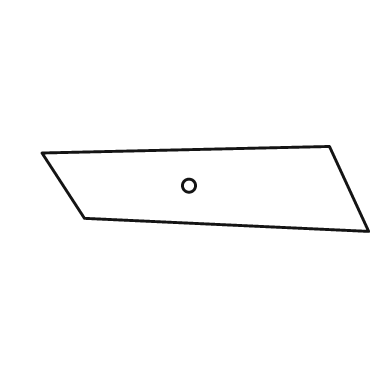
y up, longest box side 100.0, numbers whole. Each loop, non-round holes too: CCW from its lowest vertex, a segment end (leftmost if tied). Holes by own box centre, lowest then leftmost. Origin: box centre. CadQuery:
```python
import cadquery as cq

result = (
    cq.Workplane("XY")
    .moveTo(50.0, -13.0)
    .lineTo(38.0, 13.0)
    .lineTo(-50.0, 11.0)
    .lineTo(-37.0, -9.0)
    .close()
    .moveTo(-5.0, 1.0)
    .circle(2.0)
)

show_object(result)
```